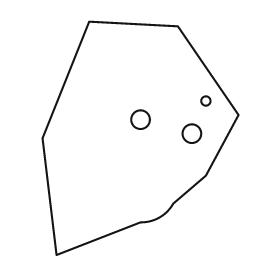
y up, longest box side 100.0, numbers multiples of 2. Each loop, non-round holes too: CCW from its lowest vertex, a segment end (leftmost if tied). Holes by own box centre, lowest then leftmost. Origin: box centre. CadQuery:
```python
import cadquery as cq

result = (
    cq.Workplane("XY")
    .moveTo(-36.0, -50.0)
    .lineTo(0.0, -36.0)
    .threePointArc((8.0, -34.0), (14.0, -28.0))
    .lineTo(28.0, -16.0)
    .lineTo(42.0, 10.0)
    .lineTo(16.0, 48.0)
    .lineTo(-22.0, 50.0)
    .lineTo(-42.0, 0.0)
    .close()
    .moveTo(22.0, 2.0)
    .circle(4.0)
    .moveTo(0.0, 8.0)
    .circle(4.0)
    .moveTo(28.0, 16.0)
    .circle(2.0)
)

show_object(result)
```